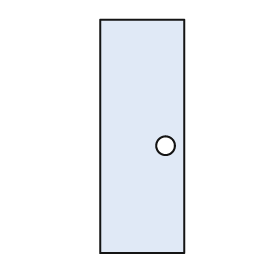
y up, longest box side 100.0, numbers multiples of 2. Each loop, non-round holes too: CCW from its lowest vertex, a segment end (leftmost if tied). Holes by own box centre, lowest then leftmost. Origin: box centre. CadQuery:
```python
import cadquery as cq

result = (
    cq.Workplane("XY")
    .moveTo(-18.0, -50.0)
    .lineTo(18.0, -50.0)
    .lineTo(18.0, 50.0)
    .lineTo(-18.0, 50.0)
    .close()
    .moveTo(10.0, -4.0)
    .circle(4.0)
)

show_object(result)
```